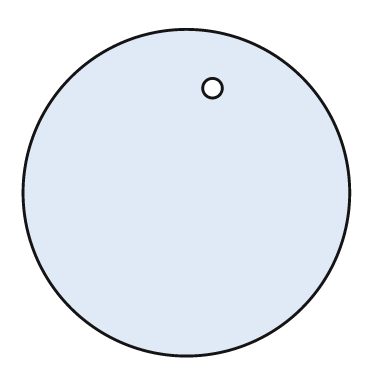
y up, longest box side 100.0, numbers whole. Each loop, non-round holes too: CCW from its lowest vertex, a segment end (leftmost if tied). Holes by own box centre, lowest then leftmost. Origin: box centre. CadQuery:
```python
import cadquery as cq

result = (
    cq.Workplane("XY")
    .moveTo(0.0, 0.0)
    .circle(50.0)
    .moveTo(8.0, 32.0)
    .circle(3.0)
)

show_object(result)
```